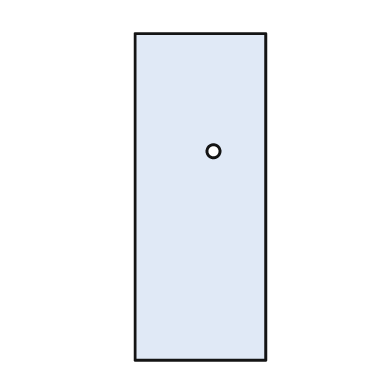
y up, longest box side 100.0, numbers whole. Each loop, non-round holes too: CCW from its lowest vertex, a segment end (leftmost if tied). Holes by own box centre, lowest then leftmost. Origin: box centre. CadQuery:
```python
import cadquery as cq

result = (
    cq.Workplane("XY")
    .moveTo(-20.0, -50.0)
    .lineTo(20.0, -50.0)
    .lineTo(20.0, 50.0)
    .lineTo(-20.0, 50.0)
    .close()
    .moveTo(4.0, 14.0)
    .circle(2.0)
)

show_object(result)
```